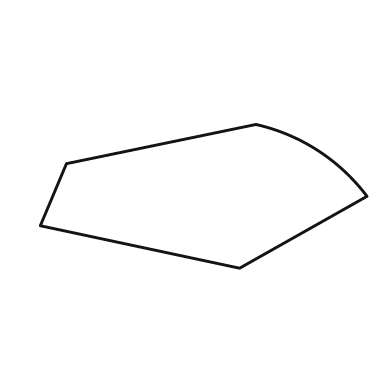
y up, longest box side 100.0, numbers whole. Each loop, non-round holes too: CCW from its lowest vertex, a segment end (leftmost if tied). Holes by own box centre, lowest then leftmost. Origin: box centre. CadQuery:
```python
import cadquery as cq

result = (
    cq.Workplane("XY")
    .moveTo(11.0, -22.0)
    .lineTo(50.0, 0.0)
    .threePointArc((35.0, 14.0), (16.0, 22.0))
    .lineTo(-42.0, 10.0)
    .lineTo(-50.0, -9.0)
    .close()
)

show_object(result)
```